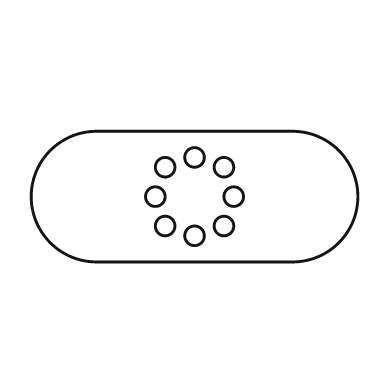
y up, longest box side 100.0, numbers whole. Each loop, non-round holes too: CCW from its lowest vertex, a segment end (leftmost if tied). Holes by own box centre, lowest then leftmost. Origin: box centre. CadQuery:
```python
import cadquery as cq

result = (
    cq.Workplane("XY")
    .moveTo(-30.0, -20.0)
    .lineTo(30.0, -20.0)
    .threePointArc((50.0, 0.0), (30.0, 20.0))
    .lineTo(-30.0, 20.0)
    .threePointArc((-50.0, 0.0), (-30.0, -20.0))
    .close()
    .moveTo(0.0, -12.0)
    .circle(3.0)
    .moveTo(-9.0, -9.0)
    .circle(3.0)
    .moveTo(9.0, -9.0)
    .circle(3.0)
    .moveTo(-12.0, 0.0)
    .circle(3.0)
    .moveTo(12.0, 0.0)
    .circle(3.0)
    .moveTo(-9.0, 9.0)
    .circle(3.0)
    .moveTo(9.0, 9.0)
    .circle(3.0)
    .moveTo(0.0, 12.0)
    .circle(3.0)
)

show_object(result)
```